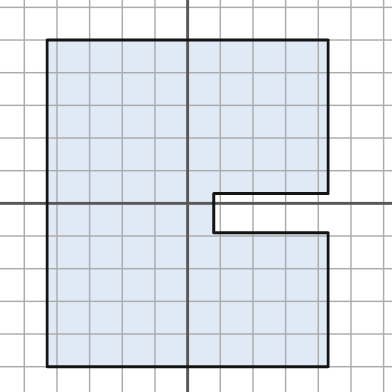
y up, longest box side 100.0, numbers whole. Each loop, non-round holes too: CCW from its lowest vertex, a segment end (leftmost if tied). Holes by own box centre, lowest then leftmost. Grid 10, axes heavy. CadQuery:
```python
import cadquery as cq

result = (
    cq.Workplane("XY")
    .moveTo(-43.0, -50.0)
    .lineTo(43.0, -50.0)
    .lineTo(43.0, -9.0)
    .lineTo(8.0, -9.0)
    .lineTo(8.0, 3.0)
    .lineTo(43.0, 3.0)
    .lineTo(43.0, 50.0)
    .lineTo(-43.0, 50.0)
    .close()
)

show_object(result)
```